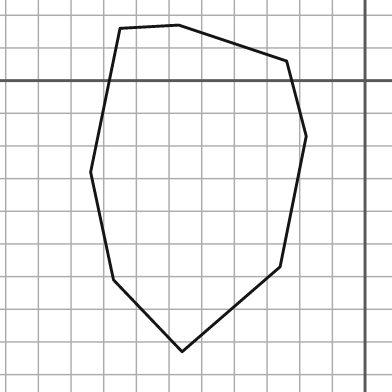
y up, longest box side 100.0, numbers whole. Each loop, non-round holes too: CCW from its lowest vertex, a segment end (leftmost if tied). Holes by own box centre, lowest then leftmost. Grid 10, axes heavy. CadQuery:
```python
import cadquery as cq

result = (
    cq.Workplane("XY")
    .moveTo(-56.0, -83.0)
    .lineTo(-26.0, -57.0)
    .lineTo(-18.0, -17.0)
    .lineTo(-24.0, 6.0)
    .lineTo(-57.0, 17.0)
    .lineTo(-75.0, 16.0)
    .lineTo(-84.0, -28.0)
    .lineTo(-77.0, -61.0)
    .close()
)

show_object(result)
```